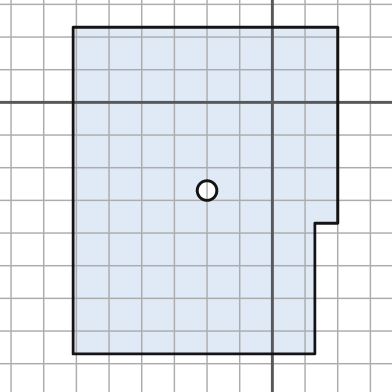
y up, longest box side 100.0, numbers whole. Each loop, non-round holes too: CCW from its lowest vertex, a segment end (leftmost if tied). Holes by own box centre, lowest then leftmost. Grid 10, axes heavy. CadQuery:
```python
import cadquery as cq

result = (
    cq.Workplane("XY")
    .moveTo(-61.0, -77.0)
    .lineTo(13.0, -77.0)
    .lineTo(13.0, -37.0)
    .lineTo(20.0, -37.0)
    .lineTo(20.0, 23.0)
    .lineTo(-61.0, 23.0)
    .close()
    .moveTo(-20.0, -27.0)
    .circle(3.0)
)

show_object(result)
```